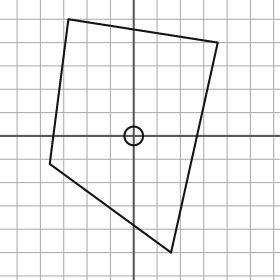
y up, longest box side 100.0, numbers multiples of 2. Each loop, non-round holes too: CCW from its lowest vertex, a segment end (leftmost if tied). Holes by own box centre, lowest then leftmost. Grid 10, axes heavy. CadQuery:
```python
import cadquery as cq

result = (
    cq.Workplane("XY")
    .moveTo(16.0, -50.0)
    .lineTo(36.0, 40.0)
    .lineTo(-28.0, 50.0)
    .lineTo(-36.0, -12.0)
    .close()
    .moveTo(0.0, 0.0)
    .circle(4.0)
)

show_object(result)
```